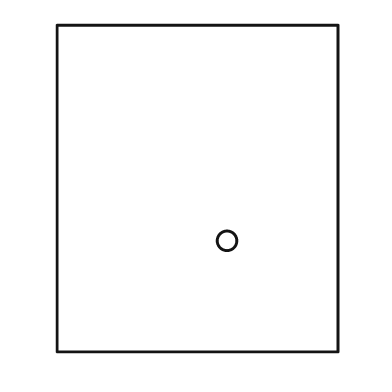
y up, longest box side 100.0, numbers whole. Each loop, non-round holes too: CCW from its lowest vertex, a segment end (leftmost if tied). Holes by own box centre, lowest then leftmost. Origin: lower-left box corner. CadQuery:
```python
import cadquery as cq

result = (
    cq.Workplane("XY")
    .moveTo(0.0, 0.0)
    .lineTo(86.0, 0.0)
    .lineTo(86.0, 100.0)
    .lineTo(0.0, 100.0)
    .close()
    .moveTo(52.0, 34.0)
    .circle(3.0)
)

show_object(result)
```